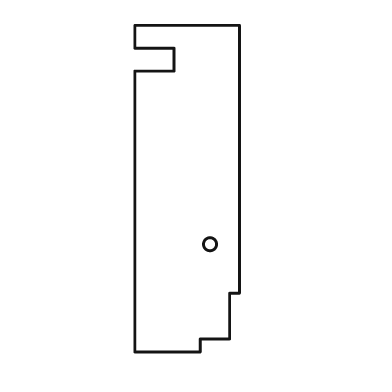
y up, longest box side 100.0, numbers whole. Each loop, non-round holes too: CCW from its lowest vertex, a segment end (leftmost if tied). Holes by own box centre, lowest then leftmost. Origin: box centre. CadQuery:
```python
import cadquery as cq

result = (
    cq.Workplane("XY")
    .moveTo(-16.0, -50.0)
    .lineTo(4.0, -50.0)
    .lineTo(4.0, -46.0)
    .lineTo(13.0, -46.0)
    .lineTo(13.0, -32.0)
    .lineTo(16.0, -32.0)
    .lineTo(16.0, 50.0)
    .lineTo(-16.0, 50.0)
    .lineTo(-16.0, 43.0)
    .lineTo(-4.0, 43.0)
    .lineTo(-4.0, 36.0)
    .lineTo(-16.0, 36.0)
    .close()
    .moveTo(7.0, -17.0)
    .circle(2.0)
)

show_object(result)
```